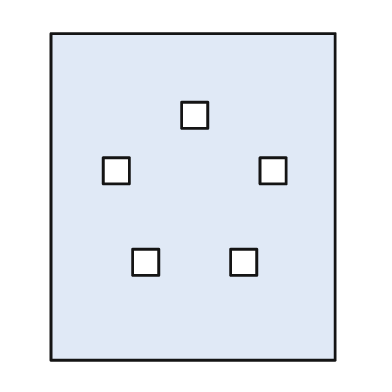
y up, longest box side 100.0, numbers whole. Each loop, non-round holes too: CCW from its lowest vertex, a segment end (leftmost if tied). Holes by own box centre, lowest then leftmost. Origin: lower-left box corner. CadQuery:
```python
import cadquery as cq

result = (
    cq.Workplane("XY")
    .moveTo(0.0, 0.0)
    .lineTo(87.0, 0.0)
    .lineTo(87.0, 100.0)
    .lineTo(0.0, 100.0)
    .close()
    .moveTo(25.0, 26.0)
    .lineTo(33.0, 26.0)
    .lineTo(33.0, 34.0)
    .lineTo(25.0, 34.0)
    .close()
    .moveTo(55.0, 26.0)
    .lineTo(63.0, 26.0)
    .lineTo(63.0, 34.0)
    .lineTo(55.0, 34.0)
    .close()
    .moveTo(16.0, 54.0)
    .lineTo(24.0, 54.0)
    .lineTo(24.0, 62.0)
    .lineTo(16.0, 62.0)
    .close()
    .moveTo(64.0, 54.0)
    .lineTo(72.0, 54.0)
    .lineTo(72.0, 62.0)
    .lineTo(64.0, 62.0)
    .close()
    .moveTo(40.0, 71.0)
    .lineTo(48.0, 71.0)
    .lineTo(48.0, 79.0)
    .lineTo(40.0, 79.0)
    .close()
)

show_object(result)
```